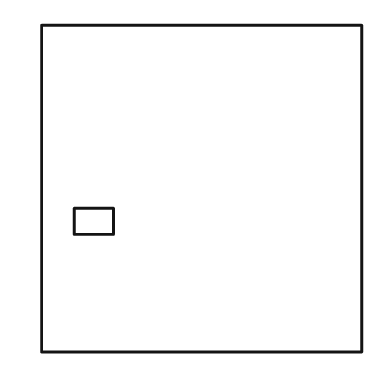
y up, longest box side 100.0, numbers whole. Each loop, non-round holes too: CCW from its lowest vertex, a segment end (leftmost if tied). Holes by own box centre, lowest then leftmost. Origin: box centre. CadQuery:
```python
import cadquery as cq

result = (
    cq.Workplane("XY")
    .moveTo(-49.0, -50.0)
    .lineTo(49.0, -50.0)
    .lineTo(49.0, 50.0)
    .lineTo(-49.0, 50.0)
    .close()
    .moveTo(-39.0, -14.0)
    .lineTo(-27.0, -14.0)
    .lineTo(-27.0, -6.0)
    .lineTo(-39.0, -6.0)
    .close()
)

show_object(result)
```